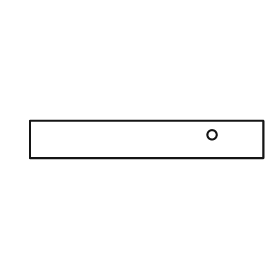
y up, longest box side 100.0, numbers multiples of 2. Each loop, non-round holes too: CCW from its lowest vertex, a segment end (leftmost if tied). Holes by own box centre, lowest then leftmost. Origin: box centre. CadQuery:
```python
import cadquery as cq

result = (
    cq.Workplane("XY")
    .moveTo(-50.0, -8.0)
    .lineTo(50.0, -8.0)
    .lineTo(50.0, 8.0)
    .lineTo(-50.0, 8.0)
    .close()
    .moveTo(28.0, 2.0)
    .circle(2.0)
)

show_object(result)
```